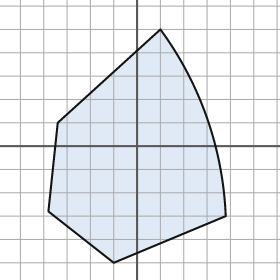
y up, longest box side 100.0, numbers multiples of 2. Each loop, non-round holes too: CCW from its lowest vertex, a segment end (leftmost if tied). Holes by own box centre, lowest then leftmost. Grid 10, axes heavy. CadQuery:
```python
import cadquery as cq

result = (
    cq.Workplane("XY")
    .moveTo(-10.0, -50.0)
    .lineTo(38.0, -30.0)
    .threePointArc((30.0, 12.0), (10.0, 50.0))
    .lineTo(-34.0, 10.0)
    .lineTo(-38.0, -28.0)
    .close()
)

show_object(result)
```